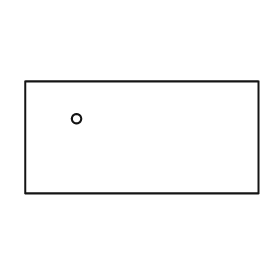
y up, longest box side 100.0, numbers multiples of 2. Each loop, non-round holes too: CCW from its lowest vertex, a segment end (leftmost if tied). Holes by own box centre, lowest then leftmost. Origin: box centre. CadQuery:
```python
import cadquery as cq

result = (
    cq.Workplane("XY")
    .moveTo(-50.0, -24.0)
    .lineTo(50.0, -24.0)
    .lineTo(50.0, 24.0)
    .lineTo(-50.0, 24.0)
    .close()
    .moveTo(-28.0, 8.0)
    .circle(2.0)
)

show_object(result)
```